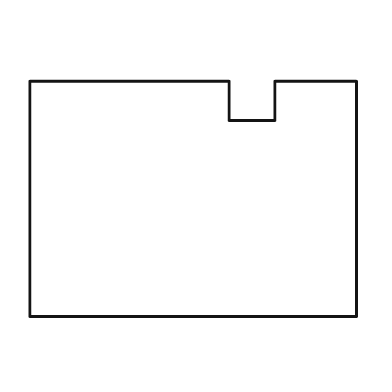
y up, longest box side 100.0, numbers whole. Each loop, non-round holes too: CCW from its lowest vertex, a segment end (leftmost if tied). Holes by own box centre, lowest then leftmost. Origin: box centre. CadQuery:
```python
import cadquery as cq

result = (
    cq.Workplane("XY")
    .moveTo(-50.0, -36.0)
    .lineTo(50.0, -36.0)
    .lineTo(50.0, 36.0)
    .lineTo(25.0, 36.0)
    .lineTo(25.0, 24.0)
    .lineTo(11.0, 24.0)
    .lineTo(11.0, 36.0)
    .lineTo(-50.0, 36.0)
    .close()
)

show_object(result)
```